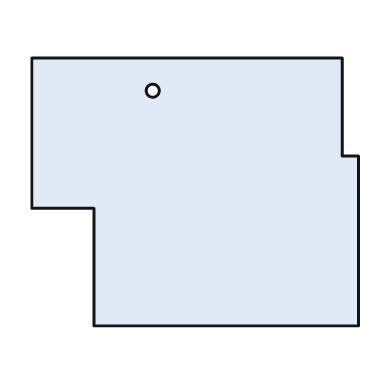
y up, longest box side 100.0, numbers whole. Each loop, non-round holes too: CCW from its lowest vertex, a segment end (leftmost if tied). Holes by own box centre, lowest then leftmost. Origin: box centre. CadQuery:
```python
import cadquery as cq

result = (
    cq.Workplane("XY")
    .moveTo(-31.0, -41.0)
    .lineTo(50.0, -41.0)
    .lineTo(50.0, 11.0)
    .lineTo(45.0, 11.0)
    .lineTo(45.0, 41.0)
    .lineTo(-50.0, 41.0)
    .lineTo(-50.0, -5.0)
    .lineTo(-31.0, -5.0)
    .close()
    .moveTo(-13.0, 31.0)
    .circle(2.0)
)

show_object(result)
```